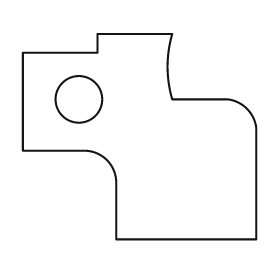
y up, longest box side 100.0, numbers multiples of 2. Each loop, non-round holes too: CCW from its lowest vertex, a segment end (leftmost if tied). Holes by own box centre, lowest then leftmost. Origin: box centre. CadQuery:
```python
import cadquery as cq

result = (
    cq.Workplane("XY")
    .moveTo(-10.0, -44.0)
    .lineTo(50.0, -44.0)
    .lineTo(50.0, 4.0)
    .threePointArc((46.0, 12.0), (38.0, 16.0))
    .lineTo(14.0, 16.0)
    .threePointArc((12.0, 30.0), (14.0, 44.0))
    .lineTo(-18.0, 44.0)
    .lineTo(-18.0, 36.0)
    .lineTo(-50.0, 36.0)
    .lineTo(-50.0, -6.0)
    .lineTo(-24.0, -6.0)
    .threePointArc((-14.0, -10.0), (-10.0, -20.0))
    .close()
    .moveTo(-26.0, 16.0)
    .circle(10.0)
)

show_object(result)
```